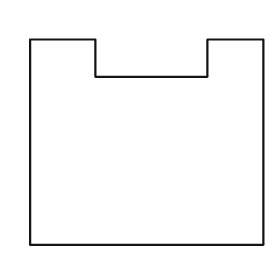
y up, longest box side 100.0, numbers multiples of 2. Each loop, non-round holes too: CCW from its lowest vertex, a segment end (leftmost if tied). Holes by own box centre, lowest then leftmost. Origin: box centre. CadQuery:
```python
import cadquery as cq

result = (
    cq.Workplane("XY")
    .moveTo(-50.0, -44.0)
    .lineTo(50.0, -44.0)
    .lineTo(50.0, 44.0)
    .lineTo(26.0, 44.0)
    .lineTo(26.0, 28.0)
    .lineTo(-22.0, 28.0)
    .lineTo(-22.0, 44.0)
    .lineTo(-50.0, 44.0)
    .close()
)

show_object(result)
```